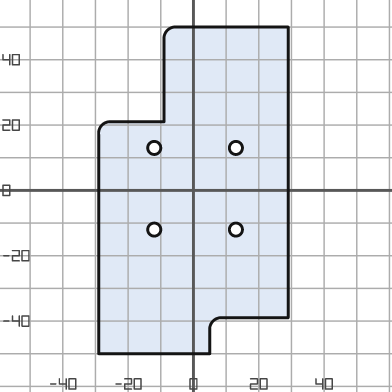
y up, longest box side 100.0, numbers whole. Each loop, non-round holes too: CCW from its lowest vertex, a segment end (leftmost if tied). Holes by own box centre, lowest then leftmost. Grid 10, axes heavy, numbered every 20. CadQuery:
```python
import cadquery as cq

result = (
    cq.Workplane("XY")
    .moveTo(-29.0, -50.0)
    .lineTo(5.0, -50.0)
    .lineTo(5.0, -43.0)
    .threePointArc((6.0, -40.0), (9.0, -39.0))
    .lineTo(29.0, -39.0)
    .lineTo(29.0, 50.0)
    .lineTo(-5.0, 50.0)
    .threePointArc((-8.0, 49.0), (-9.0, 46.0))
    .lineTo(-9.0, 21.0)
    .lineTo(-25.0, 21.0)
    .threePointArc((-28.0, 20.0), (-29.0, 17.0))
    .close()
    .moveTo(-12.0, -12.0)
    .circle(2.0)
    .moveTo(13.0, -12.0)
    .circle(2.0)
    .moveTo(-12.0, 13.0)
    .circle(2.0)
    .moveTo(13.0, 13.0)
    .circle(2.0)
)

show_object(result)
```